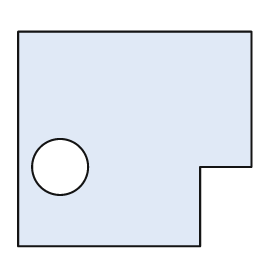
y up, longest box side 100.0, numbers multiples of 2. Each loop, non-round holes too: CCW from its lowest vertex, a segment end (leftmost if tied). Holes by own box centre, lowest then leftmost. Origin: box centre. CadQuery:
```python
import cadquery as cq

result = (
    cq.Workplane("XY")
    .moveTo(-50.0, -46.0)
    .lineTo(28.0, -46.0)
    .lineTo(28.0, -12.0)
    .lineTo(50.0, -12.0)
    .lineTo(50.0, 46.0)
    .lineTo(-50.0, 46.0)
    .close()
    .moveTo(-32.0, -12.0)
    .circle(12.0)
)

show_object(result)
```